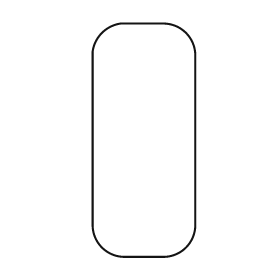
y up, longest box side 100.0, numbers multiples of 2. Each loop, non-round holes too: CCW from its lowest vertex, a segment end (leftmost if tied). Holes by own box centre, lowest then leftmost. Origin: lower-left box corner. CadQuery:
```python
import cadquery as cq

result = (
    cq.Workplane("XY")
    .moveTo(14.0, 0.0)
    .lineTo(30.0, 0.0)
    .threePointArc((40.0, 4.0), (44.0, 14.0))
    .lineTo(44.0, 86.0)
    .threePointArc((40.0, 96.0), (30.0, 100.0))
    .lineTo(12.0, 100.0)
    .threePointArc((4.0, 96.0), (0.0, 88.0))
    .lineTo(0.0, 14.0)
    .threePointArc((4.0, 4.0), (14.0, 0.0))
    .close()
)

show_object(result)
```